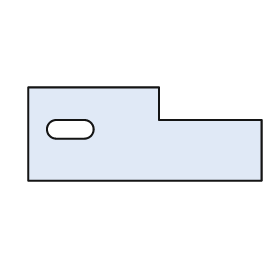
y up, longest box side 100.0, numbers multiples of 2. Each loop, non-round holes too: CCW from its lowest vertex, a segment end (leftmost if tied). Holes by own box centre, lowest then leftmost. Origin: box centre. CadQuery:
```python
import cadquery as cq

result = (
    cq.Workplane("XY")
    .moveTo(-50.0, -20.0)
    .lineTo(50.0, -20.0)
    .lineTo(50.0, 6.0)
    .lineTo(6.0, 6.0)
    .lineTo(6.0, 20.0)
    .lineTo(-50.0, 20.0)
    .close()
    .moveTo(-38.0, -2.0)
    .lineTo(-26.0, -2.0)
    .threePointArc((-22.0, 2.0), (-26.0, 6.0))
    .lineTo(-38.0, 6.0)
    .threePointArc((-42.0, 2.0), (-38.0, -2.0))
    .close()
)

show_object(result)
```